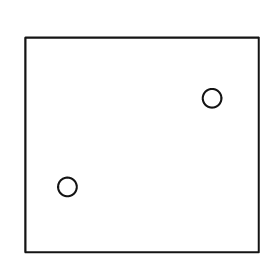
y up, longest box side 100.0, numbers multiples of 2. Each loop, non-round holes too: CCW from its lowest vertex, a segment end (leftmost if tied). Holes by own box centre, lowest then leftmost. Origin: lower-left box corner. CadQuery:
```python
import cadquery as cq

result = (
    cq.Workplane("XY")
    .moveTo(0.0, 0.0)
    .lineTo(100.0, 0.0)
    .lineTo(100.0, 92.0)
    .lineTo(0.0, 92.0)
    .close()
    .moveTo(18.0, 28.0)
    .circle(4.0)
    .moveTo(80.0, 66.0)
    .circle(4.0)
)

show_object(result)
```